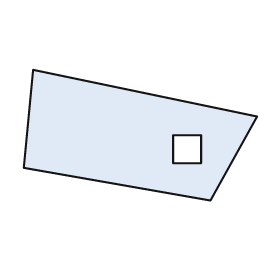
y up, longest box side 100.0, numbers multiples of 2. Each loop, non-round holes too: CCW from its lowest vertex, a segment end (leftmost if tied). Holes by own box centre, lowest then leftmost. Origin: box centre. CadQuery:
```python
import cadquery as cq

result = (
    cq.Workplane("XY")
    .moveTo(30.0, -28.0)
    .lineTo(50.0, 8.0)
    .lineTo(-46.0, 28.0)
    .lineTo(-50.0, -14.0)
    .close()
    .moveTo(14.0, -12.0)
    .lineTo(26.0, -12.0)
    .lineTo(26.0, 0.0)
    .lineTo(14.0, 0.0)
    .close()
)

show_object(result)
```